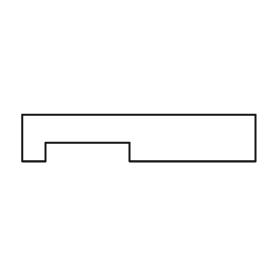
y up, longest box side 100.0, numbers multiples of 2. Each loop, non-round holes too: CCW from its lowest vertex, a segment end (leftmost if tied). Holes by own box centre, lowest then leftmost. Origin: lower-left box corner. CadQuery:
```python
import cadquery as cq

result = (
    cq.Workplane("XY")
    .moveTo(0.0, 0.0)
    .lineTo(10.0, 0.0)
    .lineTo(10.0, 8.0)
    .lineTo(46.0, 8.0)
    .lineTo(46.0, 0.0)
    .lineTo(100.0, 0.0)
    .lineTo(100.0, 20.0)
    .lineTo(0.0, 20.0)
    .close()
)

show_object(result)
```